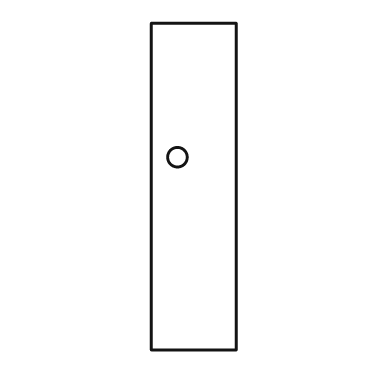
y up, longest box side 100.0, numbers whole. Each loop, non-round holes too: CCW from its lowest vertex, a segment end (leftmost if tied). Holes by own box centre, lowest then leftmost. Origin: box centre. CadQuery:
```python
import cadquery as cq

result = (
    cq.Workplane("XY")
    .moveTo(-13.0, -50.0)
    .lineTo(13.0, -50.0)
    .lineTo(13.0, 50.0)
    .lineTo(-13.0, 50.0)
    .close()
    .moveTo(-5.0, 9.0)
    .circle(3.0)
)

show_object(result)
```